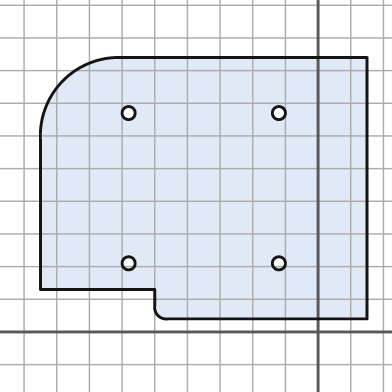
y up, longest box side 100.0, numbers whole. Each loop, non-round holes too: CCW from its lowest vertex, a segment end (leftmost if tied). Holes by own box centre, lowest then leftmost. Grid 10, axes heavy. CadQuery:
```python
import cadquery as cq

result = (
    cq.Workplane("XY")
    .moveTo(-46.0, 4.0)
    .lineTo(15.0, 4.0)
    .lineTo(15.0, 84.0)
    .lineTo(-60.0, 84.0)
    .threePointArc((-78.0, 77.0), (-85.0, 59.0))
    .lineTo(-85.0, 13.0)
    .lineTo(-50.0, 13.0)
    .lineTo(-50.0, 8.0)
    .threePointArc((-49.0, 5.0), (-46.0, 4.0))
    .close()
    .moveTo(-58.0, 21.0)
    .circle(2.0)
    .moveTo(-12.0, 21.0)
    .circle(2.0)
    .moveTo(-58.0, 67.0)
    .circle(2.0)
    .moveTo(-12.0, 67.0)
    .circle(2.0)
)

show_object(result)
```